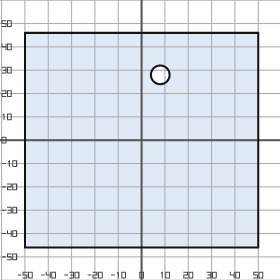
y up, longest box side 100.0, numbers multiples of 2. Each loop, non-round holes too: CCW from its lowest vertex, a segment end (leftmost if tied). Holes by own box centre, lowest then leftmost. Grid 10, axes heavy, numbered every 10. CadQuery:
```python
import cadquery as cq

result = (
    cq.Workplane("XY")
    .moveTo(-50.0, -46.0)
    .lineTo(50.0, -46.0)
    .lineTo(50.0, 46.0)
    .lineTo(-50.0, 46.0)
    .close()
    .moveTo(8.0, 28.0)
    .circle(4.0)
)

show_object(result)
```